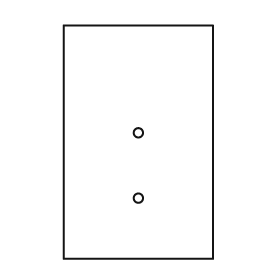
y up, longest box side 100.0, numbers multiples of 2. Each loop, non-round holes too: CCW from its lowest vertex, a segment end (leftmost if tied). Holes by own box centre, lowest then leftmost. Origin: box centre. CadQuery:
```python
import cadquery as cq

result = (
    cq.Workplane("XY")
    .moveTo(-32.0, -50.0)
    .lineTo(32.0, -50.0)
    .lineTo(32.0, 50.0)
    .lineTo(-32.0, 50.0)
    .close()
    .moveTo(0.0, -24.0)
    .circle(2.0)
    .moveTo(0.0, 4.0)
    .circle(2.0)
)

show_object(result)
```